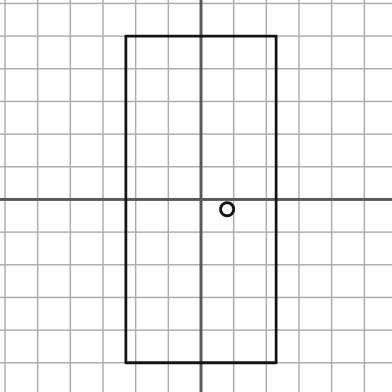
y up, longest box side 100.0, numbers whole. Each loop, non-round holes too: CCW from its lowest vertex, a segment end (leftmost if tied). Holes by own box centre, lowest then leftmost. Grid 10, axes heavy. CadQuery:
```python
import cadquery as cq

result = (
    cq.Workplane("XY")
    .moveTo(-23.0, -50.0)
    .lineTo(23.0, -50.0)
    .lineTo(23.0, 50.0)
    .lineTo(-23.0, 50.0)
    .close()
    .moveTo(8.0, -3.0)
    .circle(2.0)
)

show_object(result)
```